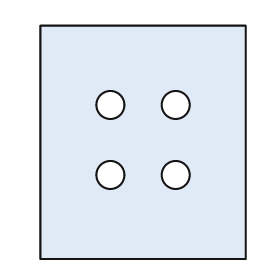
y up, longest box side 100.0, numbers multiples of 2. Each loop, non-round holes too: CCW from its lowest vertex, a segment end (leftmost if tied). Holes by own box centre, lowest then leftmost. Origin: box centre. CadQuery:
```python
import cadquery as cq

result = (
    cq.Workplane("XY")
    .moveTo(-44.0, -50.0)
    .lineTo(44.0, -50.0)
    .lineTo(44.0, 50.0)
    .lineTo(-44.0, 50.0)
    .close()
    .moveTo(-14.0, -14.0)
    .circle(6.0)
    .moveTo(14.0, -14.0)
    .circle(6.0)
    .moveTo(-14.0, 16.0)
    .circle(6.0)
    .moveTo(14.0, 16.0)
    .circle(6.0)
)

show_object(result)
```